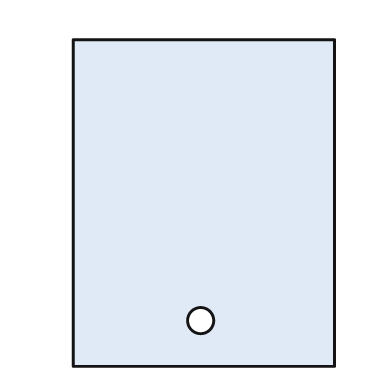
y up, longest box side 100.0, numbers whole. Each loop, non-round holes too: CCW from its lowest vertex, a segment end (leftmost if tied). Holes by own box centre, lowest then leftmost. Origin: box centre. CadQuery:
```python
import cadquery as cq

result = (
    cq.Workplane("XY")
    .moveTo(-40.0, -50.0)
    .lineTo(40.0, -50.0)
    .lineTo(40.0, 50.0)
    .lineTo(-40.0, 50.0)
    .close()
    .moveTo(-1.0, -36.0)
    .circle(4.0)
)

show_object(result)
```